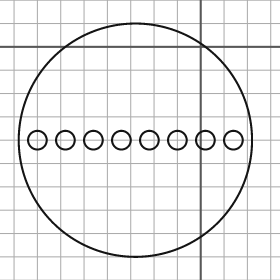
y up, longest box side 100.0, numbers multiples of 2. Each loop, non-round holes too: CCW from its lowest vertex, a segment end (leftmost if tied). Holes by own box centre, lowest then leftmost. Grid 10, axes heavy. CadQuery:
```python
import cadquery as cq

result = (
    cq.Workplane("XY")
    .moveTo(-28.0, -40.0)
    .circle(50.0)
    .moveTo(-70.0, -40.0)
    .circle(4.0)
    .moveTo(-58.0, -40.0)
    .circle(4.0)
    .moveTo(-46.0, -40.0)
    .circle(4.0)
    .moveTo(-34.0, -40.0)
    .circle(4.0)
    .moveTo(-22.0, -40.0)
    .circle(4.0)
    .moveTo(-10.0, -40.0)
    .circle(4.0)
    .moveTo(2.0, -40.0)
    .circle(4.0)
    .moveTo(14.0, -40.0)
    .circle(4.0)
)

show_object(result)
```